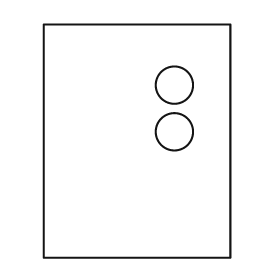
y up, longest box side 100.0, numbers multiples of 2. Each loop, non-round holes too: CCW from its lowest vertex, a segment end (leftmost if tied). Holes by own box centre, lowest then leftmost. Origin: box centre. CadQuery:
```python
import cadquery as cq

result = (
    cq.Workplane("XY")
    .moveTo(-40.0, -50.0)
    .lineTo(40.0, -50.0)
    .lineTo(40.0, 50.0)
    .lineTo(-40.0, 50.0)
    .close()
    .moveTo(16.0, 4.0)
    .circle(8.0)
    .moveTo(16.0, 24.0)
    .circle(8.0)
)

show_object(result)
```